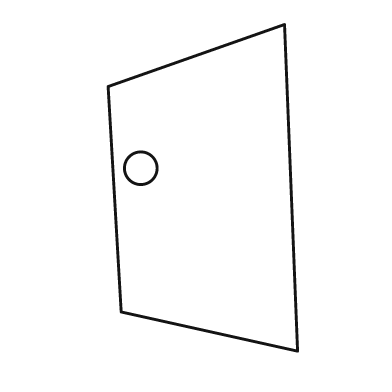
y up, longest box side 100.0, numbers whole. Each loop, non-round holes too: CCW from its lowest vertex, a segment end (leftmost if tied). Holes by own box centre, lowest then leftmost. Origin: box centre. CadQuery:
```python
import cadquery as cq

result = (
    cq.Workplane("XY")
    .moveTo(29.0, -50.0)
    .lineTo(25.0, 50.0)
    .lineTo(-29.0, 31.0)
    .lineTo(-25.0, -38.0)
    .close()
    .moveTo(-19.0, 6.0)
    .circle(5.0)
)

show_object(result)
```